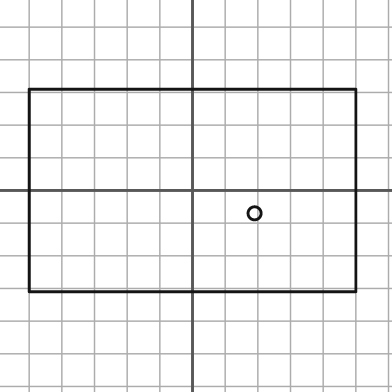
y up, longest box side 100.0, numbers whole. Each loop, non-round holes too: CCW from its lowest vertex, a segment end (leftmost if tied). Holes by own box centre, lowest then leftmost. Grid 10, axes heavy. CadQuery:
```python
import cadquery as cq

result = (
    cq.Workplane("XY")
    .moveTo(-50.0, -31.0)
    .lineTo(50.0, -31.0)
    .lineTo(50.0, 31.0)
    .lineTo(-50.0, 31.0)
    .close()
    .moveTo(19.0, -7.0)
    .circle(2.0)
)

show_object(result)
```